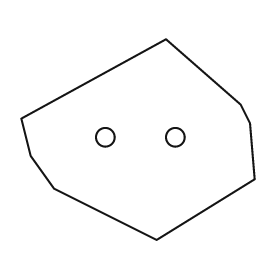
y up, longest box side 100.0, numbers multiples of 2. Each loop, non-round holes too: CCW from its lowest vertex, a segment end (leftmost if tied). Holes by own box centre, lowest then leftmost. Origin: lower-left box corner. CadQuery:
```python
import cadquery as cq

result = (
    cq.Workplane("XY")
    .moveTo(58.0, 0.0)
    .lineTo(100.0, 26.0)
    .lineTo(98.0, 50.0)
    .lineTo(94.0, 58.0)
    .lineTo(62.0, 86.0)
    .lineTo(0.0, 52.0)
    .lineTo(4.0, 36.0)
    .lineTo(14.0, 22.0)
    .close()
    .moveTo(36.0, 44.0)
    .circle(4.0)
    .moveTo(66.0, 44.0)
    .circle(4.0)
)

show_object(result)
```